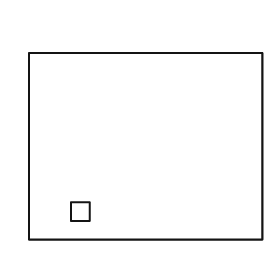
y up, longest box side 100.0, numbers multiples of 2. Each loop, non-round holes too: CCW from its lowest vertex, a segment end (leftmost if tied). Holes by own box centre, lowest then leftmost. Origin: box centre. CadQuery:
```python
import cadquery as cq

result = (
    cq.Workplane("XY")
    .moveTo(-50.0, -40.0)
    .lineTo(50.0, -40.0)
    .lineTo(50.0, 40.0)
    .lineTo(-50.0, 40.0)
    .close()
    .moveTo(-32.0, -32.0)
    .lineTo(-24.0, -32.0)
    .lineTo(-24.0, -24.0)
    .lineTo(-32.0, -24.0)
    .close()
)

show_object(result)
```